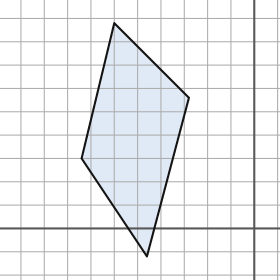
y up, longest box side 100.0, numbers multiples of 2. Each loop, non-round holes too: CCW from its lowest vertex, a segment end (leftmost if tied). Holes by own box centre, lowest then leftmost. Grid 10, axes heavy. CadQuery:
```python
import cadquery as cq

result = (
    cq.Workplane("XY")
    .moveTo(-46.0, -12.0)
    .lineTo(-28.0, 56.0)
    .lineTo(-60.0, 88.0)
    .lineTo(-74.0, 30.0)
    .close()
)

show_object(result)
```